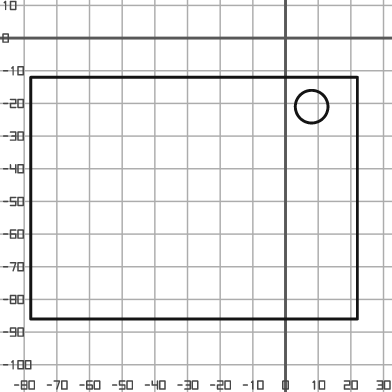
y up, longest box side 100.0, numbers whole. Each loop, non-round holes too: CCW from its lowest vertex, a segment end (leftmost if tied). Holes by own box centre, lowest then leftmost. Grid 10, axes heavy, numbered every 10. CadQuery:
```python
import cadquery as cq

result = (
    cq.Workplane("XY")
    .moveTo(-78.0, -86.0)
    .lineTo(22.0, -86.0)
    .lineTo(22.0, -12.0)
    .lineTo(-78.0, -12.0)
    .close()
    .moveTo(8.0, -21.0)
    .circle(5.0)
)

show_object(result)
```